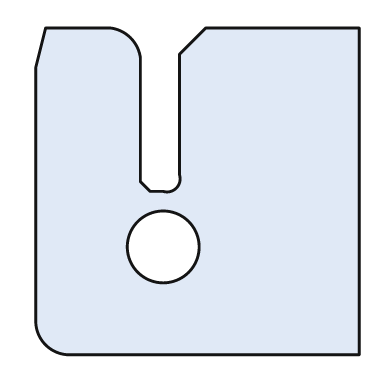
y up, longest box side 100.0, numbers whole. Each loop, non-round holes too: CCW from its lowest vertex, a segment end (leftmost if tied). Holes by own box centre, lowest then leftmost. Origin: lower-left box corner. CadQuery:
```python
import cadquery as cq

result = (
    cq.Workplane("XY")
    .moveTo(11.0, 0.0)
    .lineTo(99.0, 0.0)
    .lineTo(99.0, 100.0)
    .lineTo(52.0, 100.0)
    .lineTo(44.0, 92.0)
    .lineTo(44.0, 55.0)
    .threePointArc((43.0, 51.0), (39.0, 50.0))
    .lineTo(35.0, 50.0)
    .lineTo(32.0, 53.0)
    .lineTo(32.0, 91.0)
    .threePointArc((29.0, 97.0), (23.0, 100.0))
    .lineTo(3.0, 100.0)
    .lineTo(0.0, 88.0)
    .lineTo(0.0, 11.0)
    .threePointArc((3.0, 3.0), (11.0, 0.0))
    .close()
    .moveTo(39.0, 33.0)
    .circle(11.0)
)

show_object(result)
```